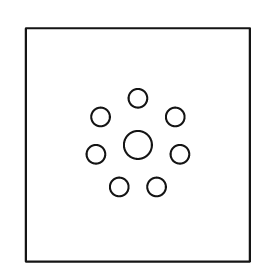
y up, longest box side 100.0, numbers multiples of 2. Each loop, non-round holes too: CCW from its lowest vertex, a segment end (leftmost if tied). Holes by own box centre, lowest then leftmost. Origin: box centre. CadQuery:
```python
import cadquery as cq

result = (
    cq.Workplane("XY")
    .moveTo(-48.0, -50.0)
    .lineTo(48.0, -50.0)
    .lineTo(48.0, 50.0)
    .lineTo(-48.0, 50.0)
    .close()
    .moveTo(-8.0, -18.0)
    .circle(4.0)
    .moveTo(8.0, -18.0)
    .circle(4.0)
    .moveTo(-18.0, -4.0)
    .circle(4.0)
    .moveTo(18.0, -4.0)
    .circle(4.0)
    .moveTo(0.0, 0.0)
    .circle(6.0)
    .moveTo(-16.0, 12.0)
    .circle(4.0)
    .moveTo(16.0, 12.0)
    .circle(4.0)
    .moveTo(0.0, 20.0)
    .circle(4.0)
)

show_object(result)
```